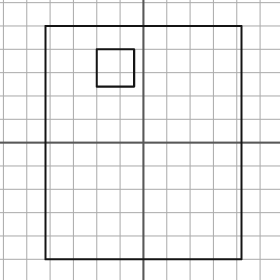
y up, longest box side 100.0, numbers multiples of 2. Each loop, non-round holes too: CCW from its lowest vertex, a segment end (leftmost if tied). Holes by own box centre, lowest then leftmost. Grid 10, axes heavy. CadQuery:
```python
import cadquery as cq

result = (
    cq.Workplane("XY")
    .moveTo(-42.0, -50.0)
    .lineTo(42.0, -50.0)
    .lineTo(42.0, 50.0)
    .lineTo(-42.0, 50.0)
    .close()
    .moveTo(-20.0, 24.0)
    .lineTo(-4.0, 24.0)
    .lineTo(-4.0, 40.0)
    .lineTo(-20.0, 40.0)
    .close()
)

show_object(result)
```